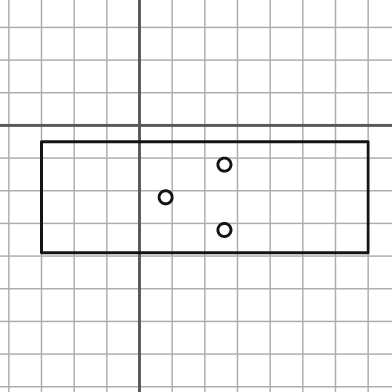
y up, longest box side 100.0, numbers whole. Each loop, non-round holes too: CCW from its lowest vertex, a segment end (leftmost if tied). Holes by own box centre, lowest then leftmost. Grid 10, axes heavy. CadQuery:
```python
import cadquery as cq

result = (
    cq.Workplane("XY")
    .moveTo(-30.0, -39.0)
    .lineTo(70.0, -39.0)
    .lineTo(70.0, -5.0)
    .lineTo(-30.0, -5.0)
    .close()
    .moveTo(26.0, -32.0)
    .circle(2.0)
    .moveTo(8.0, -22.0)
    .circle(2.0)
    .moveTo(26.0, -12.0)
    .circle(2.0)
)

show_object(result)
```